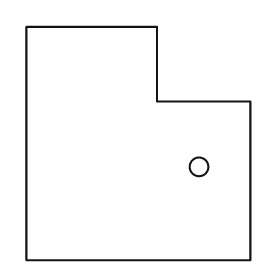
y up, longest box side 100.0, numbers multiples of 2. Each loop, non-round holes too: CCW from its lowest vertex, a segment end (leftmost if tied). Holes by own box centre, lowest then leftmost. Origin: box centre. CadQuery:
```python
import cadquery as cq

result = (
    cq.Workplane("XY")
    .moveTo(-48.0, -50.0)
    .lineTo(48.0, -50.0)
    .lineTo(48.0, 18.0)
    .lineTo(8.0, 18.0)
    .lineTo(8.0, 50.0)
    .lineTo(-48.0, 50.0)
    .close()
    .moveTo(26.0, -10.0)
    .circle(4.0)
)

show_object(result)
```